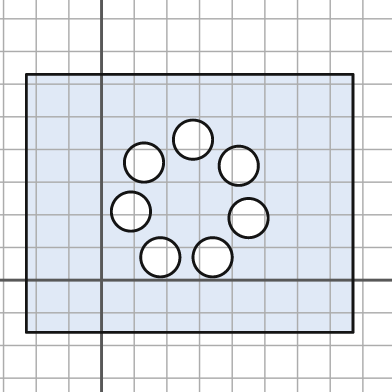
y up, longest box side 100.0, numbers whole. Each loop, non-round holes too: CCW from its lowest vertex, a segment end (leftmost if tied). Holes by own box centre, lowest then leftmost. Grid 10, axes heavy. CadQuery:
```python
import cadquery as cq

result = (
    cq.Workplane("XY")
    .moveTo(-23.0, -16.0)
    .lineTo(77.0, -16.0)
    .lineTo(77.0, 63.0)
    .lineTo(-23.0, 63.0)
    .close()
    .moveTo(18.0, 7.0)
    .circle(6.0)
    .moveTo(34.0, 7.0)
    .circle(6.0)
    .moveTo(45.0, 19.0)
    .circle(6.0)
    .moveTo(9.0, 21.0)
    .circle(6.0)
    .moveTo(42.0, 35.0)
    .circle(6.0)
    .moveTo(13.0, 36.0)
    .circle(6.0)
    .moveTo(28.0, 43.0)
    .circle(6.0)
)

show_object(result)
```